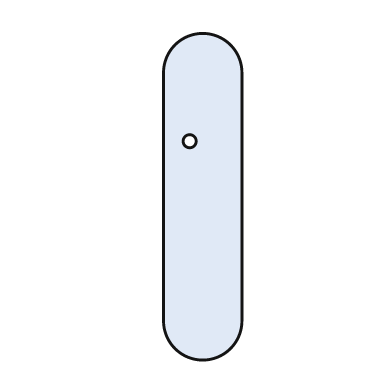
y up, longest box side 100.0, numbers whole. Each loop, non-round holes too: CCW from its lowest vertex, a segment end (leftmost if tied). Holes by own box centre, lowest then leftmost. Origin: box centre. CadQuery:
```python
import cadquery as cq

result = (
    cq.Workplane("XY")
    .moveTo(-12.0, -38.0)
    .threePointArc((0.0, -50.0), (12.0, -38.0))
    .lineTo(12.0, 38.0)
    .threePointArc((0.0, 50.0), (-12.0, 38.0))
    .close()
    .moveTo(-4.0, 17.0)
    .circle(2.0)
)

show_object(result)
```